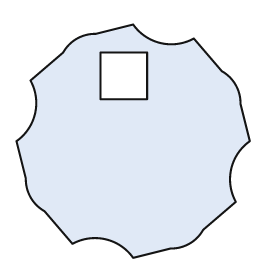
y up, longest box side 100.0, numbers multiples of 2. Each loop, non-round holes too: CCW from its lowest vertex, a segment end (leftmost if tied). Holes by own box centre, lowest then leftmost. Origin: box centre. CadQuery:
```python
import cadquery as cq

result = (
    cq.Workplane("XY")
    .moveTo(0.0, -50.0)
    .lineTo(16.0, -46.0)
    .threePointArc((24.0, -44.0), (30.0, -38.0))
    .lineTo(44.0, -26.0)
    .threePointArc((42.0, -12.0), (50.0, 0.0))
    .lineTo(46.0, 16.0)
    .threePointArc((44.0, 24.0), (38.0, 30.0))
    .lineTo(26.0, 44.0)
    .threePointArc((12.0, 42.0), (0.0, 50.0))
    .lineTo(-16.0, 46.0)
    .threePointArc((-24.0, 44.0), (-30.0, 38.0))
    .lineTo(-44.0, 26.0)
    .threePointArc((-42.0, 12.0), (-50.0, 0.0))
    .lineTo(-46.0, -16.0)
    .threePointArc((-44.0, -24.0), (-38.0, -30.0))
    .lineTo(-26.0, -44.0)
    .threePointArc((-12.0, -42.0), (0.0, -50.0))
    .close()
    .moveTo(-14.0, 18.0)
    .lineTo(6.0, 18.0)
    .lineTo(6.0, 38.0)
    .lineTo(-14.0, 38.0)
    .close()
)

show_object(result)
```